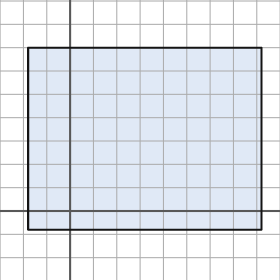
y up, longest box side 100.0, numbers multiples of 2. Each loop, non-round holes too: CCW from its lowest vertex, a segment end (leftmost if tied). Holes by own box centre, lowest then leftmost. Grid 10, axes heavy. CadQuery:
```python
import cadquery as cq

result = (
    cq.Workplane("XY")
    .moveTo(-18.0, -8.0)
    .lineTo(82.0, -8.0)
    .lineTo(82.0, 70.0)
    .lineTo(-18.0, 70.0)
    .close()
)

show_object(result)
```